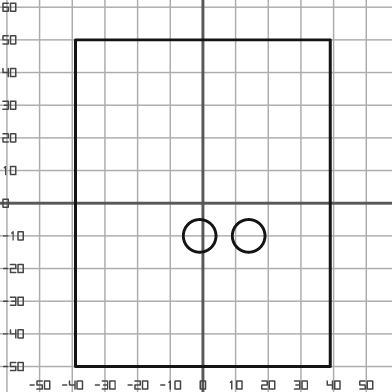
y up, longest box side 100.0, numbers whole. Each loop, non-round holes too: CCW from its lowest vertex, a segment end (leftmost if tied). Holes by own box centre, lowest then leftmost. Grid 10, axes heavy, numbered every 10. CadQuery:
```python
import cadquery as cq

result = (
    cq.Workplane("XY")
    .moveTo(-39.0, -50.0)
    .lineTo(39.0, -50.0)
    .lineTo(39.0, 50.0)
    .lineTo(-39.0, 50.0)
    .close()
    .moveTo(-1.0, -10.0)
    .circle(5.0)
    .moveTo(14.0, -10.0)
    .circle(5.0)
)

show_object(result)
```